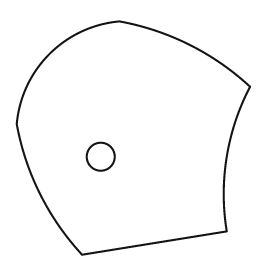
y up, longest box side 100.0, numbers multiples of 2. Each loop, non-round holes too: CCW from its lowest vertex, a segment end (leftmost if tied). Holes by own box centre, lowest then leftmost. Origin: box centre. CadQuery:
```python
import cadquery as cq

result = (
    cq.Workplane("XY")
    .moveTo(-22.0, -50.0)
    .lineTo(40.0, -40.0)
    .threePointArc((40.0, -8.0), (50.0, 22.0))
    .threePointArc((24.0, 40.0), (-6.0, 50.0))
    .threePointArc((-36.0, 36.0), (-50.0, 6.0))
    .threePointArc((-40.0, -24.0), (-22.0, -50.0))
    .close()
    .moveTo(-14.0, -8.0)
    .circle(6.0)
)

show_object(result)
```